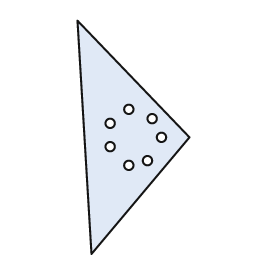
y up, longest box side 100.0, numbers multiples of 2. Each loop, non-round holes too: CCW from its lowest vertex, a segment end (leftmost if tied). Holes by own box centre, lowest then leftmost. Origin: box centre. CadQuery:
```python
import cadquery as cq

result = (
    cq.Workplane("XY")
    .moveTo(-18.0, -50.0)
    .lineTo(24.0, 0.0)
    .lineTo(-24.0, 50.0)
    .close()
    .moveTo(-2.0, -12.0)
    .circle(2.0)
    .moveTo(6.0, -10.0)
    .circle(2.0)
    .moveTo(-10.0, -4.0)
    .circle(2.0)
    .moveTo(12.0, 0.0)
    .circle(2.0)
    .moveTo(-10.0, 6.0)
    .circle(2.0)
    .moveTo(8.0, 8.0)
    .circle(2.0)
    .moveTo(-2.0, 12.0)
    .circle(2.0)
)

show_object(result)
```